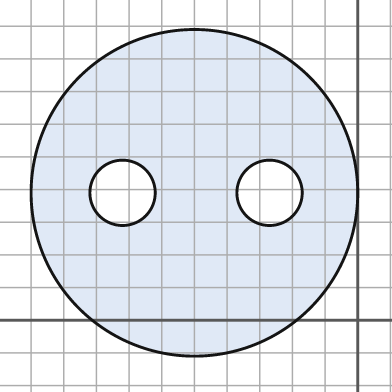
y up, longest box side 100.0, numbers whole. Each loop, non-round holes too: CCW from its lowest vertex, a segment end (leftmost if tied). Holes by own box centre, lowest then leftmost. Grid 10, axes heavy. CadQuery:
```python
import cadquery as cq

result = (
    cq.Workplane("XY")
    .moveTo(-50.0, 39.0)
    .circle(50.0)
    .moveTo(-72.0, 39.0)
    .circle(10.0)
    .moveTo(-27.0, 39.0)
    .circle(10.0)
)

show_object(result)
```